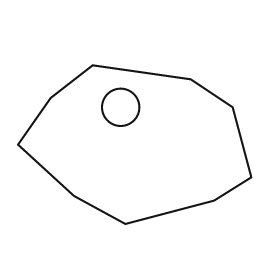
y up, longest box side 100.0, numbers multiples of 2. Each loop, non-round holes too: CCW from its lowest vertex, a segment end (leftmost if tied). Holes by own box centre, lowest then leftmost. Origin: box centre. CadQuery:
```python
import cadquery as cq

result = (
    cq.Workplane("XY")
    .moveTo(-4.0, -34.0)
    .lineTo(34.0, -24.0)
    .lineTo(50.0, -14.0)
    .lineTo(42.0, 16.0)
    .lineTo(24.0, 28.0)
    .lineTo(-18.0, 34.0)
    .lineTo(-36.0, 20.0)
    .lineTo(-50.0, 0.0)
    .lineTo(-26.0, -22.0)
    .close()
    .moveTo(-6.0, 16.0)
    .circle(8.0)
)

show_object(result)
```